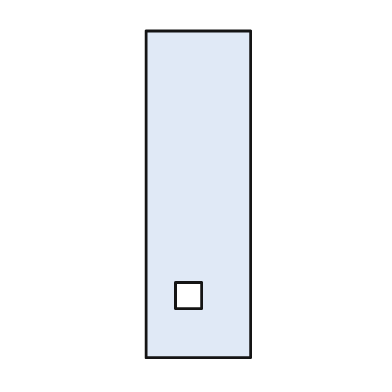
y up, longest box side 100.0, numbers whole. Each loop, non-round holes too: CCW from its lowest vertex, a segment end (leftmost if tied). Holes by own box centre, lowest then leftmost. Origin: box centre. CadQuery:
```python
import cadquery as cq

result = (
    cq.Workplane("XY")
    .moveTo(-16.0, -50.0)
    .lineTo(16.0, -50.0)
    .lineTo(16.0, 50.0)
    .lineTo(-16.0, 50.0)
    .close()
    .moveTo(-7.0, -35.0)
    .lineTo(1.0, -35.0)
    .lineTo(1.0, -27.0)
    .lineTo(-7.0, -27.0)
    .close()
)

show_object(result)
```